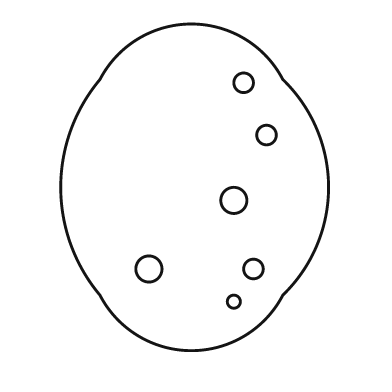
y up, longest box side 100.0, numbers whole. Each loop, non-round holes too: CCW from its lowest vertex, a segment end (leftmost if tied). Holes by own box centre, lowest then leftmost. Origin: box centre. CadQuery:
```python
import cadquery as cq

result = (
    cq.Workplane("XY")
    .moveTo(-29.0, -33.0)
    .threePointArc((-1.0, -50.0), (27.0, -33.0))
    .threePointArc((41.0, 0.0), (27.0, 33.0))
    .threePointArc((-1.0, 50.0), (-29.0, 33.0))
    .threePointArc((-41.0, 0.0), (-29.0, -33.0))
    .close()
    .moveTo(12.0, -35.0)
    .circle(2.0)
    .moveTo(-14.0, -25.0)
    .circle(4.0)
    .moveTo(18.0, -25.0)
    .circle(3.0)
    .moveTo(12.0, -4.0)
    .circle(4.0)
    .moveTo(22.0, 16.0)
    .circle(3.0)
    .moveTo(15.0, 32.0)
    .circle(3.0)
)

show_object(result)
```